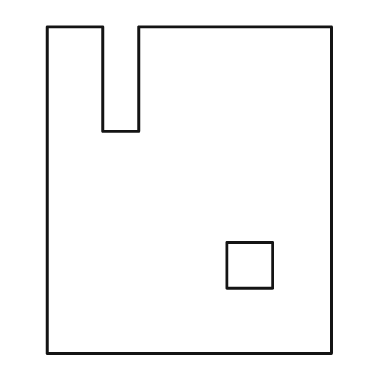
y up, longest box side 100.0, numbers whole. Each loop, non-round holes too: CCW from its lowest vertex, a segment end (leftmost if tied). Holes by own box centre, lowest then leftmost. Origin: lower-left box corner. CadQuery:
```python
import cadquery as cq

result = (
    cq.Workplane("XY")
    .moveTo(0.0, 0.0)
    .lineTo(87.0, 0.0)
    .lineTo(87.0, 100.0)
    .lineTo(28.0, 100.0)
    .lineTo(28.0, 68.0)
    .lineTo(17.0, 68.0)
    .lineTo(17.0, 100.0)
    .lineTo(0.0, 100.0)
    .close()
    .moveTo(55.0, 20.0)
    .lineTo(69.0, 20.0)
    .lineTo(69.0, 34.0)
    .lineTo(55.0, 34.0)
    .close()
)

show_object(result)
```